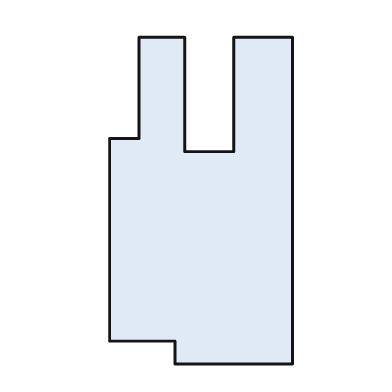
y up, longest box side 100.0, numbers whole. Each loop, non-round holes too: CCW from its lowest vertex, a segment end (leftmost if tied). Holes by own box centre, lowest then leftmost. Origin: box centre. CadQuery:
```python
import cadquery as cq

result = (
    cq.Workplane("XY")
    .moveTo(-8.0, -50.0)
    .lineTo(28.0, -50.0)
    .lineTo(28.0, 50.0)
    .lineTo(10.0, 50.0)
    .lineTo(10.0, 15.0)
    .lineTo(-5.0, 15.0)
    .lineTo(-5.0, 50.0)
    .lineTo(-19.0, 50.0)
    .lineTo(-19.0, 19.0)
    .lineTo(-28.0, 19.0)
    .lineTo(-28.0, -43.0)
    .lineTo(-8.0, -43.0)
    .close()
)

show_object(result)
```